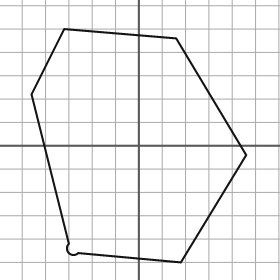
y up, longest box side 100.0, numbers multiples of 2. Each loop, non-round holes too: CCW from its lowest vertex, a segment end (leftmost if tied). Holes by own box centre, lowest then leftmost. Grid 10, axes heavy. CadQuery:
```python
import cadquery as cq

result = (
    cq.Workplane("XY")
    .moveTo(18.0, -50.0)
    .lineTo(46.0, -4.0)
    .lineTo(16.0, 46.0)
    .lineTo(-32.0, 50.0)
    .lineTo(-46.0, 22.0)
    .lineTo(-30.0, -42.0)
    .threePointArc((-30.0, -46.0), (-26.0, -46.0))
    .close()
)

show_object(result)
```